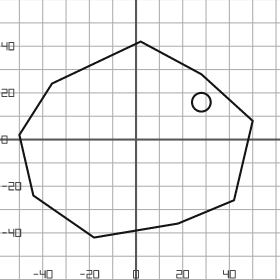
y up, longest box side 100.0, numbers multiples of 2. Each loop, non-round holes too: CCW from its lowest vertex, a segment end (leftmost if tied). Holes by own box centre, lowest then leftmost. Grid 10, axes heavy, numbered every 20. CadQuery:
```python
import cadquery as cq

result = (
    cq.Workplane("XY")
    .moveTo(-18.0, -42.0)
    .lineTo(18.0, -36.0)
    .lineTo(42.0, -26.0)
    .lineTo(50.0, 8.0)
    .lineTo(28.0, 28.0)
    .lineTo(2.0, 42.0)
    .lineTo(-36.0, 24.0)
    .lineTo(-50.0, 2.0)
    .lineTo(-44.0, -24.0)
    .close()
    .moveTo(28.0, 16.0)
    .circle(4.0)
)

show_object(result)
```